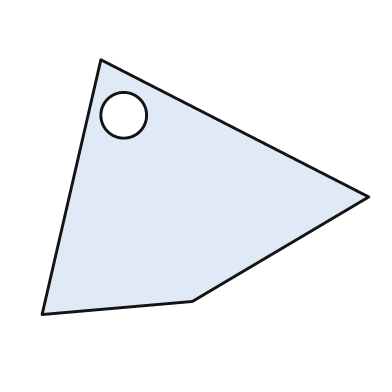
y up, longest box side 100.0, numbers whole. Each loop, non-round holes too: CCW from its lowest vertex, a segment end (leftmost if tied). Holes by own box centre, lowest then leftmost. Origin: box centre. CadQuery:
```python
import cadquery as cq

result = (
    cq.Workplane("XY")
    .moveTo(-50.0, -39.0)
    .lineTo(-4.0, -35.0)
    .lineTo(50.0, -3.0)
    .lineTo(-32.0, 39.0)
    .close()
    .moveTo(-25.0, 22.0)
    .circle(7.0)
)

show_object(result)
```